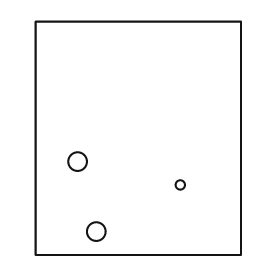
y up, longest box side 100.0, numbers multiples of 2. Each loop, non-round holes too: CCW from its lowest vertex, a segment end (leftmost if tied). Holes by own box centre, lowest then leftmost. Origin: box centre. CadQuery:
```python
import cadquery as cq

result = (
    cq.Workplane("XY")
    .moveTo(-44.0, -50.0)
    .lineTo(44.0, -50.0)
    .lineTo(44.0, 50.0)
    .lineTo(-44.0, 50.0)
    .close()
    .moveTo(-18.0, -40.0)
    .circle(4.0)
    .moveTo(18.0, -20.0)
    .circle(2.0)
    .moveTo(-26.0, -10.0)
    .circle(4.0)
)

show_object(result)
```